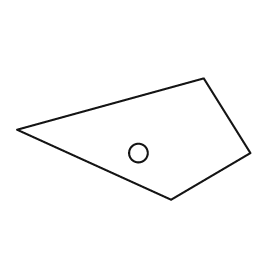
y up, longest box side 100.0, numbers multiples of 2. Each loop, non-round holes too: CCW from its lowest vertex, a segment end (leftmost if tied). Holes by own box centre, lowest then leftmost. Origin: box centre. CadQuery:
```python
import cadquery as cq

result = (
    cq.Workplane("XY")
    .moveTo(16.0, -26.0)
    .lineTo(50.0, -6.0)
    .lineTo(30.0, 26.0)
    .lineTo(-50.0, 4.0)
    .close()
    .moveTo(2.0, -6.0)
    .circle(4.0)
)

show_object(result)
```